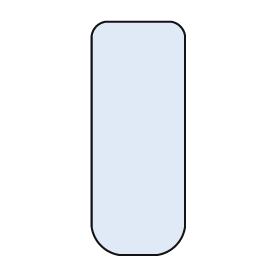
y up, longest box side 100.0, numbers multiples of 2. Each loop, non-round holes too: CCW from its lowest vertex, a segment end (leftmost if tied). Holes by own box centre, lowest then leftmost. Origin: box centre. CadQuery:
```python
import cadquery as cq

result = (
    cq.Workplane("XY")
    .moveTo(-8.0, -50.0)
    .lineTo(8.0, -50.0)
    .threePointArc((16.0, -46.0), (20.0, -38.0))
    .lineTo(20.0, 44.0)
    .threePointArc((18.0, 48.0), (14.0, 50.0))
    .lineTo(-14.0, 50.0)
    .threePointArc((-18.0, 48.0), (-20.0, 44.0))
    .lineTo(-20.0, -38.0)
    .threePointArc((-16.0, -46.0), (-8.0, -50.0))
    .close()
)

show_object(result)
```